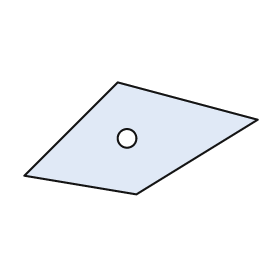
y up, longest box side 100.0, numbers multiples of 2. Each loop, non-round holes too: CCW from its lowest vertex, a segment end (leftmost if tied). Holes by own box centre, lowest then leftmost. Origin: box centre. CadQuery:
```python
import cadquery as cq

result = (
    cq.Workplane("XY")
    .moveTo(-2.0, -24.0)
    .lineTo(50.0, 8.0)
    .lineTo(-10.0, 24.0)
    .lineTo(-50.0, -16.0)
    .close()
    .moveTo(-6.0, 0.0)
    .circle(4.0)
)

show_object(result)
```